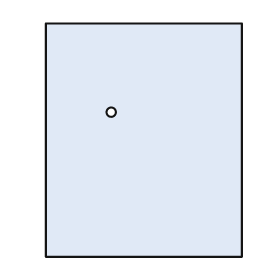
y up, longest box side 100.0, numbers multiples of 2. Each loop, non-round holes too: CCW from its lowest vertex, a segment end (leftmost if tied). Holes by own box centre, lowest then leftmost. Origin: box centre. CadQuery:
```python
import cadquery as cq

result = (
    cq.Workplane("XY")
    .moveTo(-42.0, -50.0)
    .lineTo(42.0, -50.0)
    .lineTo(42.0, 50.0)
    .lineTo(-42.0, 50.0)
    .close()
    .moveTo(-14.0, 12.0)
    .circle(2.0)
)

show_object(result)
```